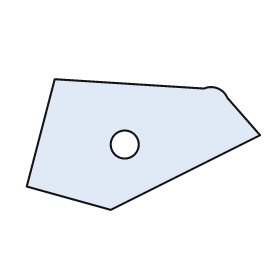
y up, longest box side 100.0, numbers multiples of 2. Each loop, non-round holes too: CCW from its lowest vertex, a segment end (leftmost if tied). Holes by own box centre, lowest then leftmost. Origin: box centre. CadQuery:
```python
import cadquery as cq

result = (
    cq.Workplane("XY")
    .moveTo(-14.0, -28.0)
    .lineTo(50.0, 4.0)
    .lineTo(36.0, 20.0)
    .threePointArc((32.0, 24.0), (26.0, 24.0))
    .lineTo(-38.0, 28.0)
    .lineTo(-50.0, -18.0)
    .close()
    .moveTo(-8.0, 0.0)
    .circle(6.0)
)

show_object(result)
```